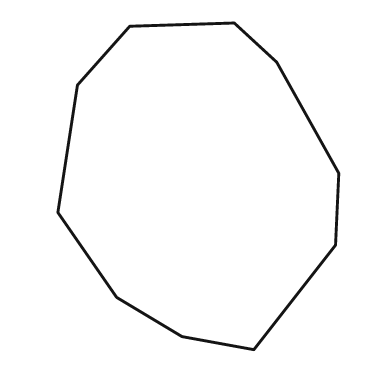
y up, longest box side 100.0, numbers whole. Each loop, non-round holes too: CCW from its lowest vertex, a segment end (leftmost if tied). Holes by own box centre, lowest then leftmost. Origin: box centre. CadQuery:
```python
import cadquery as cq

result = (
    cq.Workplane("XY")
    .moveTo(17.0, -50.0)
    .lineTo(42.0, -18.0)
    .lineTo(43.0, 4.0)
    .lineTo(24.0, 38.0)
    .lineTo(11.0, 50.0)
    .lineTo(-21.0, 49.0)
    .lineTo(-37.0, 31.0)
    .lineTo(-43.0, -8.0)
    .lineTo(-25.0, -34.0)
    .lineTo(-5.0, -46.0)
    .close()
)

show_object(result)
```